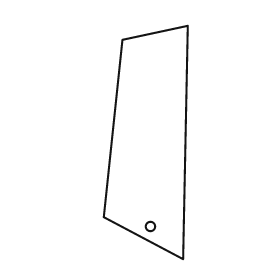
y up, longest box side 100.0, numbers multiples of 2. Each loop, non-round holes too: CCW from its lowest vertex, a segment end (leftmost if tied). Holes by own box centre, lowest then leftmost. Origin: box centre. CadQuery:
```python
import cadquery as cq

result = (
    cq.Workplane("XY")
    .moveTo(16.0, -50.0)
    .lineTo(18.0, 50.0)
    .lineTo(-10.0, 44.0)
    .lineTo(-18.0, -32.0)
    .close()
    .moveTo(2.0, -36.0)
    .circle(2.0)
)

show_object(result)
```